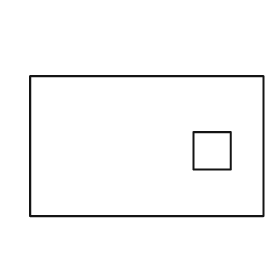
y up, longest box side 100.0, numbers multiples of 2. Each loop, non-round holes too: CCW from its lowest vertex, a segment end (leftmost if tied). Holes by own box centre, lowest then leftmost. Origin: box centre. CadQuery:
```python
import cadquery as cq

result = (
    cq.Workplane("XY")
    .moveTo(-50.0, -30.0)
    .lineTo(50.0, -30.0)
    .lineTo(50.0, 30.0)
    .lineTo(-50.0, 30.0)
    .close()
    .moveTo(20.0, -10.0)
    .lineTo(36.0, -10.0)
    .lineTo(36.0, 6.0)
    .lineTo(20.0, 6.0)
    .close()
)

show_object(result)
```